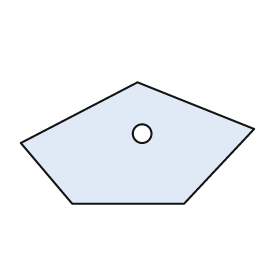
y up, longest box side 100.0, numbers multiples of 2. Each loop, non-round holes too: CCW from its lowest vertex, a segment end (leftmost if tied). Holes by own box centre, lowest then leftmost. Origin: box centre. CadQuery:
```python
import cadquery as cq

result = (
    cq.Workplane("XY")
    .moveTo(-28.0, -26.0)
    .lineTo(20.0, -26.0)
    .lineTo(50.0, 6.0)
    .lineTo(0.0, 26.0)
    .lineTo(-50.0, 0.0)
    .close()
    .moveTo(2.0, 4.0)
    .circle(4.0)
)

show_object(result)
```